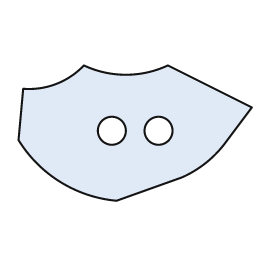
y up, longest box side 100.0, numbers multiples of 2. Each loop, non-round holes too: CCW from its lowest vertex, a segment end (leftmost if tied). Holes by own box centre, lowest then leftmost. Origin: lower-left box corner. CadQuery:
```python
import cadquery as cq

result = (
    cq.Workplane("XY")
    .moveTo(42.0, 0.0)
    .lineTo(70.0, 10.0)
    .threePointArc((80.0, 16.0), (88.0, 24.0))
    .lineTo(100.0, 40.0)
    .lineTo(64.0, 58.0)
    .threePointArc((46.0, 54.0), (28.0, 58.0))
    .threePointArc((16.0, 50.0), (2.0, 48.0))
    .lineTo(0.0, 26.0)
    .threePointArc((18.0, 8.0), (42.0, 0.0))
    .close()
    .moveTo(40.0, 30.0)
    .circle(6.0)
    .moveTo(60.0, 30.0)
    .circle(6.0)
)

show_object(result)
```